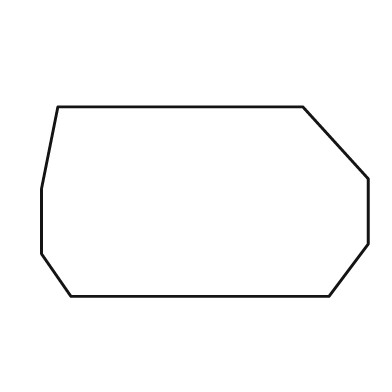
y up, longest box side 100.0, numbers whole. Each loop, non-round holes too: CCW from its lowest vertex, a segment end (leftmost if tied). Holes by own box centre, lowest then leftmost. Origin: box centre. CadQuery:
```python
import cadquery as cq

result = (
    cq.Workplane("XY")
    .moveTo(-41.0, -29.0)
    .lineTo(38.0, -29.0)
    .lineTo(50.0, -13.0)
    .lineTo(50.0, 7.0)
    .lineTo(30.0, 29.0)
    .lineTo(-45.0, 29.0)
    .lineTo(-50.0, 4.0)
    .lineTo(-50.0, -16.0)
    .close()
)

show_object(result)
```